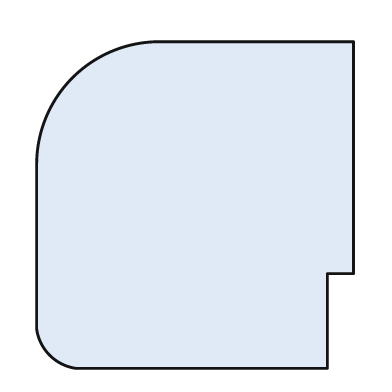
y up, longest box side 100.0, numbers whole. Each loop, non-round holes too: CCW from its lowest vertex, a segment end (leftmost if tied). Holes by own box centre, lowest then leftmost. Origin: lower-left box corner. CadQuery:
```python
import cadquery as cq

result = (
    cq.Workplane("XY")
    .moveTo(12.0, 0.0)
    .lineTo(89.0, 0.0)
    .lineTo(89.0, 29.0)
    .lineTo(97.0, 29.0)
    .lineTo(97.0, 100.0)
    .lineTo(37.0, 100.0)
    .threePointArc((11.0, 89.0), (0.0, 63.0))
    .lineTo(0.0, 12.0)
    .threePointArc((4.0, 4.0), (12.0, 0.0))
    .close()
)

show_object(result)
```